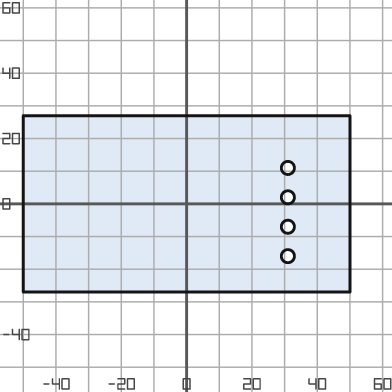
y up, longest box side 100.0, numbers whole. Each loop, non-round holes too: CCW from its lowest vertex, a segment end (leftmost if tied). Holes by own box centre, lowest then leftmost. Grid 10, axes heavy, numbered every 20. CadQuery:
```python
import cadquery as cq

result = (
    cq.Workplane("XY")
    .moveTo(-50.0, -27.0)
    .lineTo(50.0, -27.0)
    .lineTo(50.0, 27.0)
    .lineTo(-50.0, 27.0)
    .close()
    .moveTo(31.0, -16.0)
    .circle(2.0)
    .moveTo(31.0, -7.0)
    .circle(2.0)
    .moveTo(31.0, 2.0)
    .circle(2.0)
    .moveTo(31.0, 11.0)
    .circle(2.0)
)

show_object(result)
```